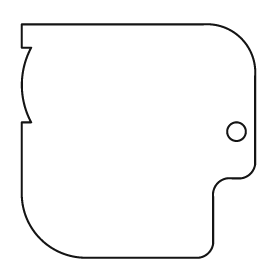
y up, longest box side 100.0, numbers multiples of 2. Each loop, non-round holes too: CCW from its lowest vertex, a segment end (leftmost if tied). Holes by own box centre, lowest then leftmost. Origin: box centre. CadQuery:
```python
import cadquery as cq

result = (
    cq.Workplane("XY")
    .moveTo(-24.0, -50.0)
    .lineTo(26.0, -50.0)
    .threePointArc((30.0, -48.0), (32.0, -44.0))
    .lineTo(32.0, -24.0)
    .threePointArc((34.0, -18.0), (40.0, -16.0))
    .lineTo(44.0, -16.0)
    .threePointArc((48.0, -14.0), (50.0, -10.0))
    .lineTo(50.0, 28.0)
    .threePointArc((44.0, 44.0), (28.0, 50.0))
    .lineTo(-50.0, 50.0)
    .lineTo(-50.0, 40.0)
    .lineTo(-46.0, 40.0)
    .threePointArc((-50.0, 24.0), (-46.0, 8.0))
    .lineTo(-50.0, 8.0)
    .lineTo(-50.0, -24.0)
    .threePointArc((-42.0, -42.0), (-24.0, -50.0))
    .close()
    .moveTo(42.0, 4.0)
    .circle(4.0)
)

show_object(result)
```